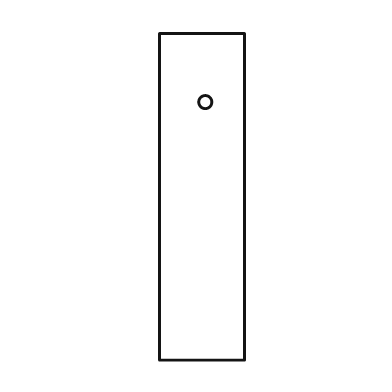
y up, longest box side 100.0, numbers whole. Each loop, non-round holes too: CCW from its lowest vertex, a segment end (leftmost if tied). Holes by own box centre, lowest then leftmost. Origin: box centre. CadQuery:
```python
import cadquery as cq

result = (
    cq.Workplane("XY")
    .moveTo(-13.0, -50.0)
    .lineTo(13.0, -50.0)
    .lineTo(13.0, 50.0)
    .lineTo(-13.0, 50.0)
    .close()
    .moveTo(1.0, 29.0)
    .circle(2.0)
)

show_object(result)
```